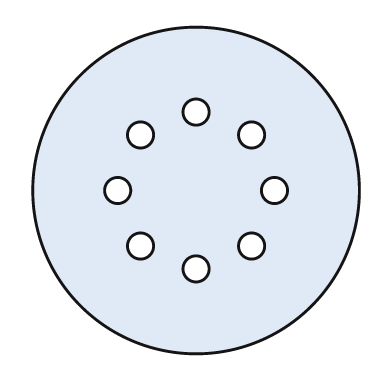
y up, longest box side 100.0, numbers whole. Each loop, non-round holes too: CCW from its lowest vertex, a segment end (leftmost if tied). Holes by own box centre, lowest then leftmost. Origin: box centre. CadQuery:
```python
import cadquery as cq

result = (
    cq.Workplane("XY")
    .moveTo(0.0, 0.0)
    .circle(50.0)
    .moveTo(0.0, -24.0)
    .circle(4.0)
    .moveTo(-17.0, -17.0)
    .circle(4.0)
    .moveTo(17.0, -17.0)
    .circle(4.0)
    .moveTo(-24.0, 0.0)
    .circle(4.0)
    .moveTo(24.0, 0.0)
    .circle(4.0)
    .moveTo(-17.0, 17.0)
    .circle(4.0)
    .moveTo(17.0, 17.0)
    .circle(4.0)
    .moveTo(0.0, 24.0)
    .circle(4.0)
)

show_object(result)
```